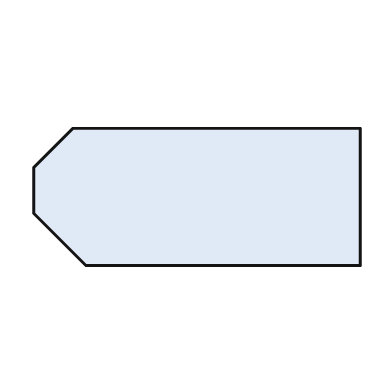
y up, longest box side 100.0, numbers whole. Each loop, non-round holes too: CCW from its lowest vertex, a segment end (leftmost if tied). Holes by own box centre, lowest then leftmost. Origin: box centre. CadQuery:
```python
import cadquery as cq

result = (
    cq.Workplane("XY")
    .moveTo(-34.0, -21.0)
    .lineTo(50.0, -21.0)
    .lineTo(50.0, 21.0)
    .lineTo(-38.0, 21.0)
    .lineTo(-50.0, 9.0)
    .lineTo(-50.0, -5.0)
    .close()
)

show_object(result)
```